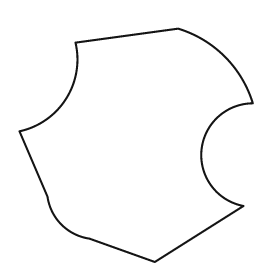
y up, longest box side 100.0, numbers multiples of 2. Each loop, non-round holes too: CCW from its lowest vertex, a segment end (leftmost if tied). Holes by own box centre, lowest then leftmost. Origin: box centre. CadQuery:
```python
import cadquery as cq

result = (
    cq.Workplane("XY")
    .moveTo(8.0, -50.0)
    .lineTo(46.0, -26.0)
    .threePointArc((28.0, -2.0), (50.0, 18.0))
    .threePointArc((38.0, 38.0), (18.0, 50.0))
    .lineTo(-26.0, 44.0)
    .threePointArc((-30.0, 20.0), (-50.0, 6.0))
    .lineTo(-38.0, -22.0)
    .threePointArc((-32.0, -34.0), (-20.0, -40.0))
    .close()
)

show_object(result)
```